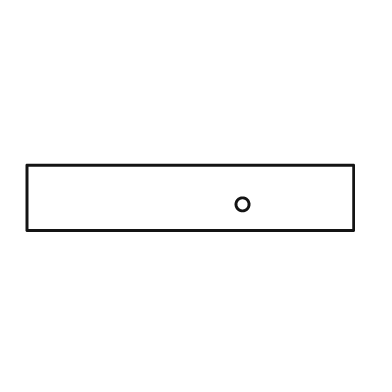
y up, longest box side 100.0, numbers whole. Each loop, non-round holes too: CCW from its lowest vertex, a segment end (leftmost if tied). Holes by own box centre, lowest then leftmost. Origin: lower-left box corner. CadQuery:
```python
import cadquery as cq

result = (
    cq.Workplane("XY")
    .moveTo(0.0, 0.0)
    .lineTo(100.0, 0.0)
    .lineTo(100.0, 20.0)
    .lineTo(0.0, 20.0)
    .close()
    .moveTo(66.0, 8.0)
    .circle(2.0)
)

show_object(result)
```